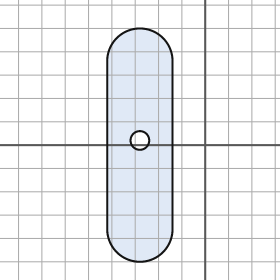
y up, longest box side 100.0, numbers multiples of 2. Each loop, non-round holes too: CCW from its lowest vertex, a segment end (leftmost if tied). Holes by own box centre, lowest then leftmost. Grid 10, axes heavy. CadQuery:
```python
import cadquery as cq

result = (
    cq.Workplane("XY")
    .moveTo(-42.0, -36.0)
    .threePointArc((-28.0, -50.0), (-14.0, -36.0))
    .lineTo(-14.0, 36.0)
    .threePointArc((-28.0, 50.0), (-42.0, 36.0))
    .close()
    .moveTo(-28.0, 2.0)
    .circle(4.0)
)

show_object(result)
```